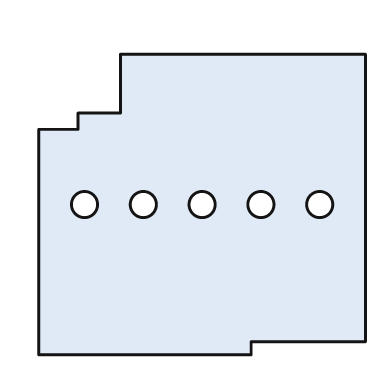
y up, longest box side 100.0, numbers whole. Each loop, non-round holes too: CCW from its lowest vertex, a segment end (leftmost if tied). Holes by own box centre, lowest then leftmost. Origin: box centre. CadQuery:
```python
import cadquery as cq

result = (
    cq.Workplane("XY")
    .moveTo(-50.0, -46.0)
    .lineTo(15.0, -46.0)
    .lineTo(15.0, -42.0)
    .lineTo(50.0, -42.0)
    .lineTo(50.0, 46.0)
    .lineTo(-25.0, 46.0)
    .lineTo(-25.0, 28.0)
    .lineTo(-38.0, 28.0)
    .lineTo(-38.0, 23.0)
    .lineTo(-50.0, 23.0)
    .close()
    .moveTo(-36.0, 0.0)
    .circle(4.0)
    .moveTo(-18.0, 0.0)
    .circle(4.0)
    .moveTo(0.0, 0.0)
    .circle(4.0)
    .moveTo(18.0, 0.0)
    .circle(4.0)
    .moveTo(36.0, 0.0)
    .circle(4.0)
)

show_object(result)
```